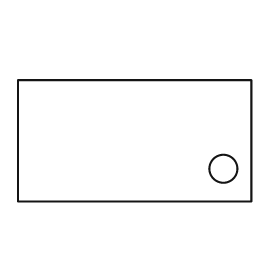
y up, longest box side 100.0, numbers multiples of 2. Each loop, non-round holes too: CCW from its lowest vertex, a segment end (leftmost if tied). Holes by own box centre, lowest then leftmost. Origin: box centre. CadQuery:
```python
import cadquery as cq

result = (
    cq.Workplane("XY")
    .moveTo(-50.0, -26.0)
    .lineTo(50.0, -26.0)
    .lineTo(50.0, 26.0)
    .lineTo(-50.0, 26.0)
    .close()
    .moveTo(38.0, -12.0)
    .circle(6.0)
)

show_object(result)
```